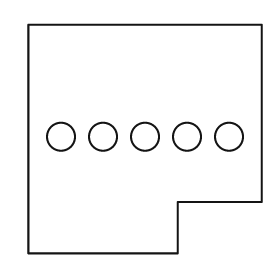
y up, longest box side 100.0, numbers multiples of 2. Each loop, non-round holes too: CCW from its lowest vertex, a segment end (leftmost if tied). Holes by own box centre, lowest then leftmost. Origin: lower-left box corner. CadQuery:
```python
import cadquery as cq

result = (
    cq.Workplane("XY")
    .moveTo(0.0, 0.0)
    .lineTo(64.0, 0.0)
    .lineTo(64.0, 22.0)
    .lineTo(100.0, 22.0)
    .lineTo(100.0, 98.0)
    .lineTo(0.0, 98.0)
    .close()
    .moveTo(14.0, 50.0)
    .circle(6.0)
    .moveTo(32.0, 50.0)
    .circle(6.0)
    .moveTo(50.0, 50.0)
    .circle(6.0)
    .moveTo(68.0, 50.0)
    .circle(6.0)
    .moveTo(86.0, 50.0)
    .circle(6.0)
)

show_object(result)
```